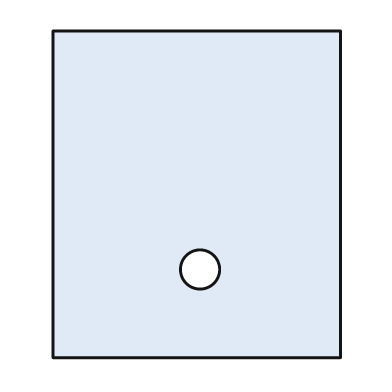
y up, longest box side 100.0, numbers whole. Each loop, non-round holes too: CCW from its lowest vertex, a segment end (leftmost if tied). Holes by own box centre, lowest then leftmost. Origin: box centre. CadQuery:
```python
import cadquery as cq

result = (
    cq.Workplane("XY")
    .moveTo(-44.0, -50.0)
    .lineTo(44.0, -50.0)
    .lineTo(44.0, 50.0)
    .lineTo(-44.0, 50.0)
    .close()
    .moveTo(1.0, -23.0)
    .circle(6.0)
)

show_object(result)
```